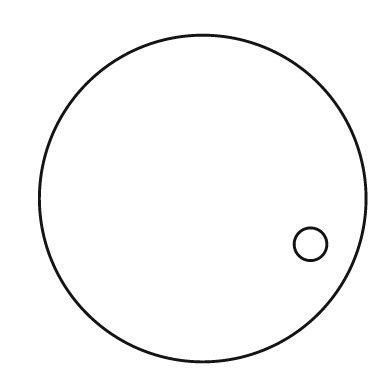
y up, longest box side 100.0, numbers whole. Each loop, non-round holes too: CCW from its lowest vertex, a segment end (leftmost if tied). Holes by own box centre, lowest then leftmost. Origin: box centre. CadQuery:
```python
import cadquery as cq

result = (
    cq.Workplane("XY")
    .moveTo(0.0, 0.0)
    .circle(50.0)
    .moveTo(33.0, -14.0)
    .circle(5.0)
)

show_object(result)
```